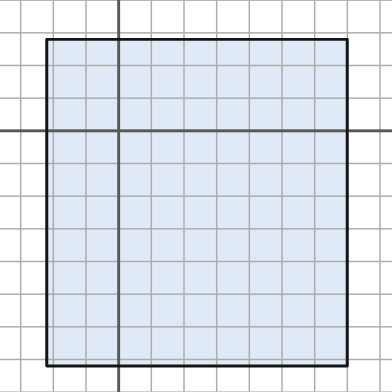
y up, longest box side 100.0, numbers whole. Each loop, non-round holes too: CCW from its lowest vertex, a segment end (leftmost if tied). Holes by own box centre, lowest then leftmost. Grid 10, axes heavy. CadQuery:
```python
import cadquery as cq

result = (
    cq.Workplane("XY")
    .moveTo(-22.0, -72.0)
    .lineTo(70.0, -72.0)
    .lineTo(70.0, 28.0)
    .lineTo(-22.0, 28.0)
    .close()
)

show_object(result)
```